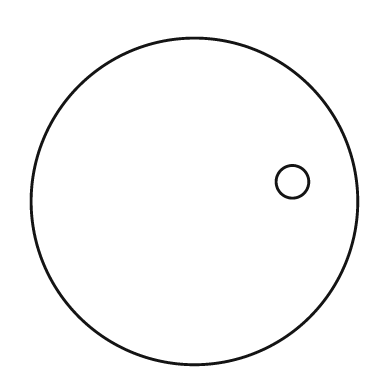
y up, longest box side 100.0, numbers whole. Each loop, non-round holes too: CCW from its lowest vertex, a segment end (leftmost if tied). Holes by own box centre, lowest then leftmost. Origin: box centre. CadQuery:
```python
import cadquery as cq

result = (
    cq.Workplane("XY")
    .moveTo(0.0, 0.0)
    .circle(50.0)
    .moveTo(30.0, 6.0)
    .circle(5.0)
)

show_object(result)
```